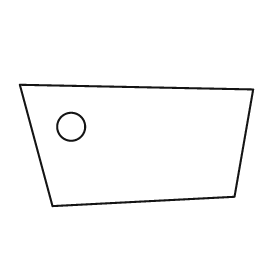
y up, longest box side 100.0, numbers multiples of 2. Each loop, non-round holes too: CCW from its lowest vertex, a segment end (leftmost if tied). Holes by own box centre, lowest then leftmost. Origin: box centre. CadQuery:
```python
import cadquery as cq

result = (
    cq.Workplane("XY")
    .moveTo(-36.0, -26.0)
    .lineTo(42.0, -22.0)
    .lineTo(50.0, 24.0)
    .lineTo(-50.0, 26.0)
    .close()
    .moveTo(-28.0, 8.0)
    .circle(6.0)
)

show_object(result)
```